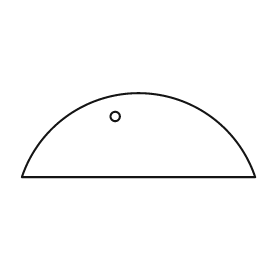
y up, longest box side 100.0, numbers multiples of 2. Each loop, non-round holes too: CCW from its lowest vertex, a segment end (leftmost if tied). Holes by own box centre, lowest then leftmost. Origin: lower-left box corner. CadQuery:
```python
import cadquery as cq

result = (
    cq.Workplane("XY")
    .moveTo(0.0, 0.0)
    .lineTo(100.0, 0.0)
    .threePointArc((50.0, 36.0), (0.0, 0.0))
    .close()
    .moveTo(40.0, 26.0)
    .circle(2.0)
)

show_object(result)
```